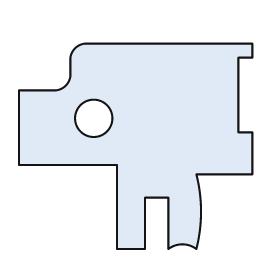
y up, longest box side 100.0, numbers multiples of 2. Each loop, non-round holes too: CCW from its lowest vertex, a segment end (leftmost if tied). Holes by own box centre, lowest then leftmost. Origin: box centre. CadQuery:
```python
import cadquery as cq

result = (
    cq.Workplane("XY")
    .moveTo(-8.0, -44.0)
    .lineTo(4.0, -44.0)
    .lineTo(4.0, -22.0)
    .lineTo(14.0, -22.0)
    .lineTo(14.0, -44.0)
    .threePointArc((20.0, -42.0), (26.0, -44.0))
    .threePointArc((28.0, -28.0), (26.0, -12.0))
    .lineTo(50.0, -12.0)
    .lineTo(50.0, 6.0)
    .lineTo(44.0, 6.0)
    .lineTo(44.0, 38.0)
    .lineTo(50.0, 38.0)
    .lineTo(50.0, 44.0)
    .lineTo(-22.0, 44.0)
    .threePointArc((-26.0, 42.0), (-28.0, 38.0))
    .lineTo(-28.0, 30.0)
    .threePointArc((-30.0, 26.0), (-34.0, 24.0))
    .lineTo(-50.0, 24.0)
    .lineTo(-50.0, -8.0)
    .lineTo(-8.0, -8.0)
    .close()
    .moveTo(-18.0, 12.0)
    .circle(8.0)
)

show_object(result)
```